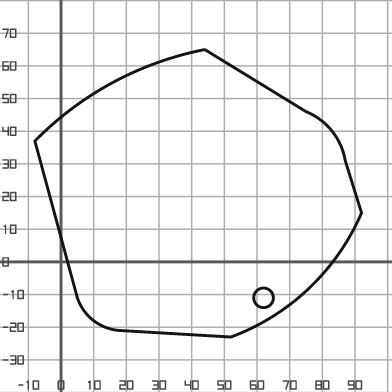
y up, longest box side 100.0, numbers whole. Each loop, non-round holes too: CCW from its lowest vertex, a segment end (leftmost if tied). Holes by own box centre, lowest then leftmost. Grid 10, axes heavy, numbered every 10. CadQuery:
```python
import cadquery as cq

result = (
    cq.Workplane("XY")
    .moveTo(52.0, -23.0)
    .threePointArc((76.0, -8.0), (92.0, 15.0))
    .lineTo(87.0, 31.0)
    .threePointArc((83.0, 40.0), (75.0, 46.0))
    .lineTo(44.0, 65.0)
    .threePointArc((16.0, 55.0), (-8.0, 37.0))
    .lineTo(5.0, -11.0)
    .threePointArc((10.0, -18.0), (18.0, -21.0))
    .close()
    .moveTo(62.0, -11.0)
    .circle(3.0)
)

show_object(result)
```